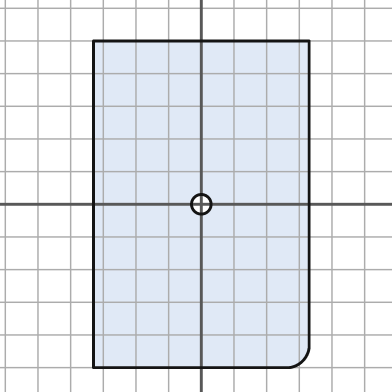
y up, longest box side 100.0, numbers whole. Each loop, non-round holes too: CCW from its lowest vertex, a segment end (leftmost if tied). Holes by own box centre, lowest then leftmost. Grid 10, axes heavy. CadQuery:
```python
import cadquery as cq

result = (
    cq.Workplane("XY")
    .moveTo(-33.0, -50.0)
    .lineTo(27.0, -50.0)
    .threePointArc((31.0, -48.0), (33.0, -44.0))
    .lineTo(33.0, 50.0)
    .lineTo(-33.0, 50.0)
    .close()
    .moveTo(0.0, 0.0)
    .circle(3.0)
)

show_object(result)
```